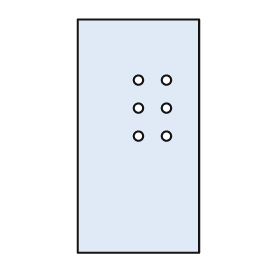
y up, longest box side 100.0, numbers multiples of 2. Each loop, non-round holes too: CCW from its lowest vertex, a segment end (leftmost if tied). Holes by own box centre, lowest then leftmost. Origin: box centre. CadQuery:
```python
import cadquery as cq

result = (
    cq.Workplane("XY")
    .moveTo(-26.0, -50.0)
    .lineTo(26.0, -50.0)
    .lineTo(26.0, 50.0)
    .lineTo(-26.0, 50.0)
    .close()
    .moveTo(0.0, 0.0)
    .circle(2.0)
    .moveTo(12.0, 0.0)
    .circle(2.0)
    .moveTo(0.0, 12.0)
    .circle(2.0)
    .moveTo(12.0, 12.0)
    .circle(2.0)
    .moveTo(0.0, 24.0)
    .circle(2.0)
    .moveTo(12.0, 24.0)
    .circle(2.0)
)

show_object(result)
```